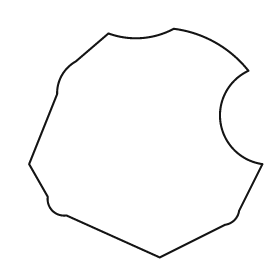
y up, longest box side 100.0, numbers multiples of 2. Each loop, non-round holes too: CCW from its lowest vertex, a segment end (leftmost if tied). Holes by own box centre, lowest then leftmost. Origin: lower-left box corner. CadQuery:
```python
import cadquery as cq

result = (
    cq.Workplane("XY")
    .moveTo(56.0, 0.0)
    .lineTo(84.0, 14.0)
    .threePointArc((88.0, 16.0), (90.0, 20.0))
    .lineTo(100.0, 40.0)
    .threePointArc((82.0, 58.0), (94.0, 80.0))
    .threePointArc((80.0, 92.0), (62.0, 98.0))
    .threePointArc((48.0, 94.0), (34.0, 96.0))
    .lineTo(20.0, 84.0)
    .threePointArc((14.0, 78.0), (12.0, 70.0))
    .lineTo(0.0, 40.0)
    .lineTo(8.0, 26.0)
    .threePointArc((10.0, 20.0), (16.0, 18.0))
    .close()
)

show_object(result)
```